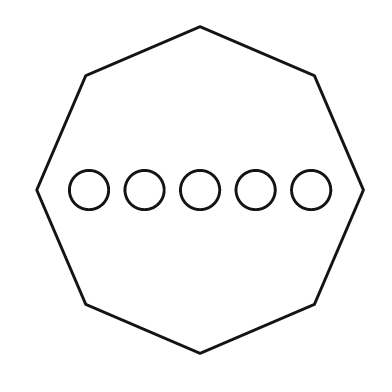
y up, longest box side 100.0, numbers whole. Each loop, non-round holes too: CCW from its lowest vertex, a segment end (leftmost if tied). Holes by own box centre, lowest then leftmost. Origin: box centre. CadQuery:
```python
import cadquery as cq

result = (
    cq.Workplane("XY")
    .moveTo(0.0, -50.0)
    .lineTo(35.0, -35.0)
    .lineTo(50.0, 0.0)
    .lineTo(35.0, 35.0)
    .lineTo(0.0, 50.0)
    .lineTo(-35.0, 35.0)
    .lineTo(-50.0, 0.0)
    .lineTo(-35.0, -35.0)
    .close()
    .moveTo(-34.0, 0.0)
    .circle(6.0)
    .moveTo(-17.0, 0.0)
    .circle(6.0)
    .moveTo(0.0, 0.0)
    .circle(6.0)
    .moveTo(17.0, 0.0)
    .circle(6.0)
    .moveTo(34.0, 0.0)
    .circle(6.0)
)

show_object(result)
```